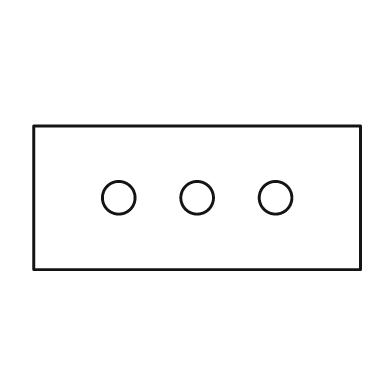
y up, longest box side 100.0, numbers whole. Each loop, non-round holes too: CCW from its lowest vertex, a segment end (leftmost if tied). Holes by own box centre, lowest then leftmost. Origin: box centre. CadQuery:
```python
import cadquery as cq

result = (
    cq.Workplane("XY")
    .moveTo(-50.0, -22.0)
    .lineTo(50.0, -22.0)
    .lineTo(50.0, 22.0)
    .lineTo(-50.0, 22.0)
    .close()
    .moveTo(-24.0, 0.0)
    .circle(5.0)
    .moveTo(0.0, 0.0)
    .circle(5.0)
    .moveTo(24.0, 0.0)
    .circle(5.0)
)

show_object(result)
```